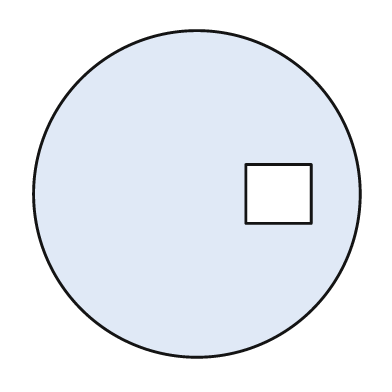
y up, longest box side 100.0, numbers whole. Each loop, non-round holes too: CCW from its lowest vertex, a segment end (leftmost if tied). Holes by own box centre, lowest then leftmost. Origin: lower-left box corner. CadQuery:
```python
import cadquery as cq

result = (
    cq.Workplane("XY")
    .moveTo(50.0, 50.0)
    .circle(50.0)
    .moveTo(65.0, 41.0)
    .lineTo(85.0, 41.0)
    .lineTo(85.0, 59.0)
    .lineTo(65.0, 59.0)
    .close()
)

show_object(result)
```